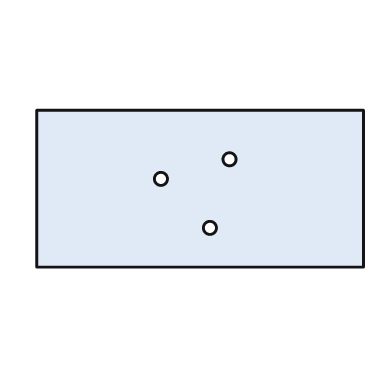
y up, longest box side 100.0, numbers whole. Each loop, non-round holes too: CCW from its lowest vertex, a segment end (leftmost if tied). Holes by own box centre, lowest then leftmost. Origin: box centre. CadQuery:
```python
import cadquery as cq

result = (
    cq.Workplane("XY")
    .moveTo(-50.0, -24.0)
    .lineTo(50.0, -24.0)
    .lineTo(50.0, 24.0)
    .lineTo(-50.0, 24.0)
    .close()
    .moveTo(3.0, -12.0)
    .circle(2.0)
    .moveTo(-12.0, 3.0)
    .circle(2.0)
    .moveTo(9.0, 9.0)
    .circle(2.0)
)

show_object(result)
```